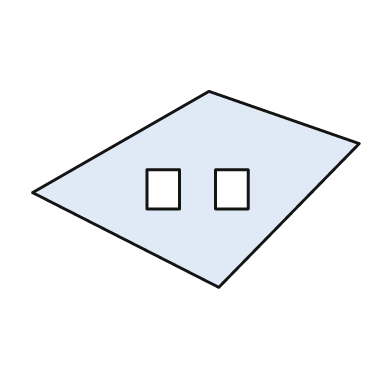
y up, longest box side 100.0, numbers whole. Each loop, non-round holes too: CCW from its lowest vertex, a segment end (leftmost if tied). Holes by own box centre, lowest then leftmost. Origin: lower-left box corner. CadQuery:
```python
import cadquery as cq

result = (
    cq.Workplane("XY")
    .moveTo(57.0, 0.0)
    .lineTo(100.0, 44.0)
    .lineTo(54.0, 60.0)
    .lineTo(0.0, 29.0)
    .close()
    .moveTo(35.0, 24.0)
    .lineTo(45.0, 24.0)
    .lineTo(45.0, 36.0)
    .lineTo(35.0, 36.0)
    .close()
    .moveTo(56.0, 24.0)
    .lineTo(66.0, 24.0)
    .lineTo(66.0, 36.0)
    .lineTo(56.0, 36.0)
    .close()
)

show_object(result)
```